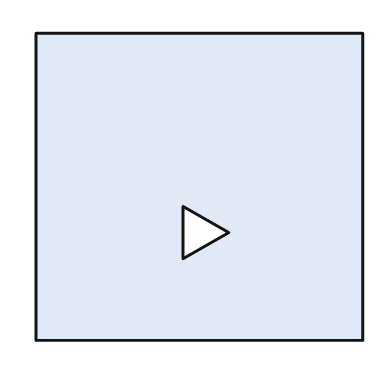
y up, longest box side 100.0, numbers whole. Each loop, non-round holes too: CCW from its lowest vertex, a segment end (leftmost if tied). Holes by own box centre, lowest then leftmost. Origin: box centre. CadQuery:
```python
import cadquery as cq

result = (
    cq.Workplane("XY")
    .moveTo(-50.0, -47.0)
    .lineTo(50.0, -47.0)
    .lineTo(50.0, 47.0)
    .lineTo(-50.0, 47.0)
    .close()
    .moveTo(-5.0, -22.0)
    .lineTo(9.0, -14.0)
    .lineTo(-5.0, -6.0)
    .close()
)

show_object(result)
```